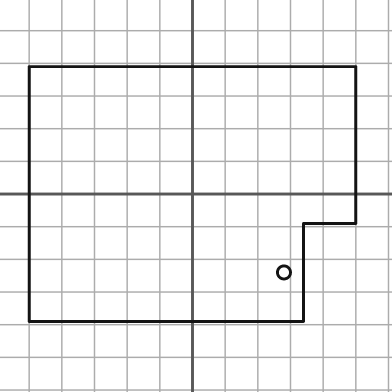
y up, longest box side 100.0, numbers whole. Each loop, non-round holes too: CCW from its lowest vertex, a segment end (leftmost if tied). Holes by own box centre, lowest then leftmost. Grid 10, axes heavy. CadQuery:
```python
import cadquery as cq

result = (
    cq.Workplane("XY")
    .moveTo(-50.0, -39.0)
    .lineTo(34.0, -39.0)
    .lineTo(34.0, -9.0)
    .lineTo(50.0, -9.0)
    .lineTo(50.0, 39.0)
    .lineTo(-50.0, 39.0)
    .close()
    .moveTo(28.0, -24.0)
    .circle(2.0)
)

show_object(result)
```